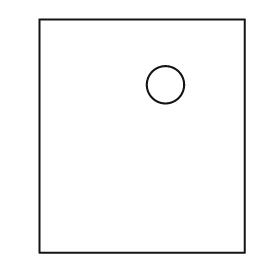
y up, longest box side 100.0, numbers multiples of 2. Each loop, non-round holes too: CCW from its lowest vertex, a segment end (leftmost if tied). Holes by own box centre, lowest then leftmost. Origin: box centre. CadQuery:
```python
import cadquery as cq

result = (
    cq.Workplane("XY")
    .moveTo(-44.0, -50.0)
    .lineTo(44.0, -50.0)
    .lineTo(44.0, 50.0)
    .lineTo(-44.0, 50.0)
    .close()
    .moveTo(10.0, 22.0)
    .circle(8.0)
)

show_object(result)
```